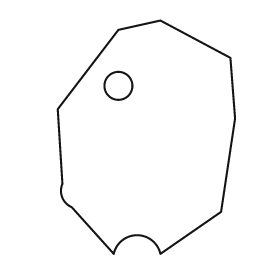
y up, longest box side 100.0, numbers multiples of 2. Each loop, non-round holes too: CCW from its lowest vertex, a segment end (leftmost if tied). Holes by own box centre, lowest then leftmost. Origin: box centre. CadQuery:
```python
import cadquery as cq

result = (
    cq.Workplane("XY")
    .moveTo(-14.0, -50.0)
    .threePointArc((-4.0, -42.0), (6.0, -50.0))
    .lineTo(32.0, -32.0)
    .lineTo(38.0, 8.0)
    .lineTo(36.0, 34.0)
    .lineTo(6.0, 50.0)
    .lineTo(-12.0, 46.0)
    .lineTo(-38.0, 12.0)
    .lineTo(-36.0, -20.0)
    .threePointArc((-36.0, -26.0), (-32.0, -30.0))
    .close()
    .moveTo(-12.0, 22.0)
    .circle(6.0)
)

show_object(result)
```